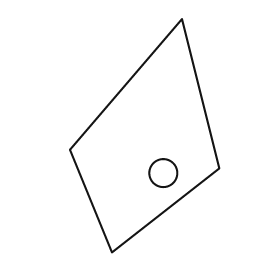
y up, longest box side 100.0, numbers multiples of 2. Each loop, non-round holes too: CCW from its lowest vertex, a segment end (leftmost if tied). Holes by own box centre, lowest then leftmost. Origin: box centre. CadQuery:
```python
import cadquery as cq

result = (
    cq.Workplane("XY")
    .moveTo(-14.0, -50.0)
    .lineTo(32.0, -14.0)
    .lineTo(16.0, 50.0)
    .lineTo(-32.0, -6.0)
    .close()
    .moveTo(8.0, -16.0)
    .circle(6.0)
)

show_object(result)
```